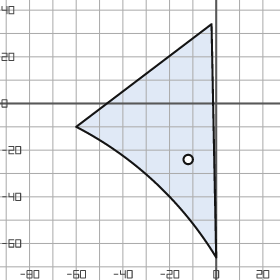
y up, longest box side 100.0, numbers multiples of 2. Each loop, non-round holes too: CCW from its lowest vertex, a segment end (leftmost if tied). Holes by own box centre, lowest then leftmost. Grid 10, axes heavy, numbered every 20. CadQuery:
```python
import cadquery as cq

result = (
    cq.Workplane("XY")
    .moveTo(0.0, -66.0)
    .lineTo(-2.0, 34.0)
    .lineTo(-60.0, -10.0)
    .threePointArc((-26.0, -34.0), (0.0, -66.0))
    .close()
    .moveTo(-12.0, -24.0)
    .circle(2.0)
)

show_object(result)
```